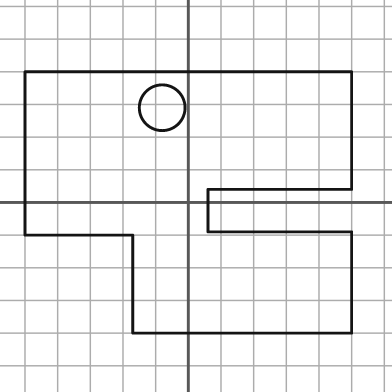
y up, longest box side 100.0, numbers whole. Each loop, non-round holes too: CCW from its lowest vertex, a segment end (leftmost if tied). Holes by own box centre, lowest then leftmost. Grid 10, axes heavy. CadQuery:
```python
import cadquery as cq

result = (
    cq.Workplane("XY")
    .moveTo(-17.0, -40.0)
    .lineTo(50.0, -40.0)
    .lineTo(50.0, -9.0)
    .lineTo(6.0, -9.0)
    .lineTo(6.0, 4.0)
    .lineTo(50.0, 4.0)
    .lineTo(50.0, 40.0)
    .lineTo(-50.0, 40.0)
    .lineTo(-50.0, -10.0)
    .lineTo(-17.0, -10.0)
    .close()
    .moveTo(-8.0, 29.0)
    .circle(7.0)
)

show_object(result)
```